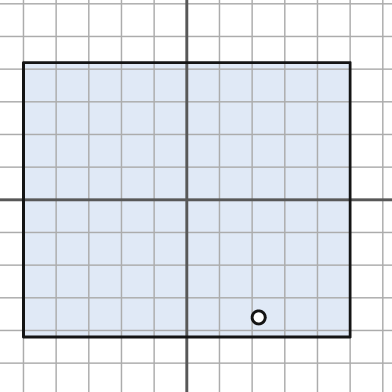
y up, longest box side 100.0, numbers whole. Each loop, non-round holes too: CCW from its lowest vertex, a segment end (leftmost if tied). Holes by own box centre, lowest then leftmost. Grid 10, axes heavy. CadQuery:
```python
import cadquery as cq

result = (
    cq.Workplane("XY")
    .moveTo(-50.0, -42.0)
    .lineTo(50.0, -42.0)
    .lineTo(50.0, 42.0)
    .lineTo(-50.0, 42.0)
    .close()
    .moveTo(22.0, -36.0)
    .circle(2.0)
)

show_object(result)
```